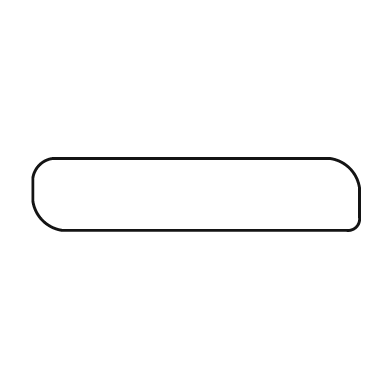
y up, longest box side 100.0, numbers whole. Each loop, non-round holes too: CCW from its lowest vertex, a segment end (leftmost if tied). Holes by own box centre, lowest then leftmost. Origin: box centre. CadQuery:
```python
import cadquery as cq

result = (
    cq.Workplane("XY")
    .moveTo(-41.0, -11.0)
    .lineTo(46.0, -11.0)
    .threePointArc((49.0, -10.0), (50.0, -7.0))
    .lineTo(50.0, 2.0)
    .threePointArc((47.0, 8.0), (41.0, 11.0))
    .lineTo(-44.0, 11.0)
    .threePointArc((-48.0, 9.0), (-50.0, 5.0))
    .lineTo(-50.0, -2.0)
    .threePointArc((-47.0, -8.0), (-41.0, -11.0))
    .close()
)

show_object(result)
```